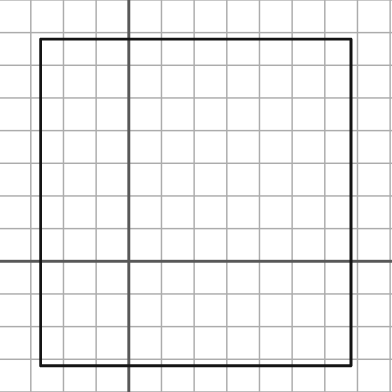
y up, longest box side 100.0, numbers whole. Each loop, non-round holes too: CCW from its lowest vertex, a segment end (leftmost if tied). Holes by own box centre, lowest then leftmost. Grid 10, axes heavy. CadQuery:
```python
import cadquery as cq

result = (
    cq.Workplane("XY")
    .moveTo(-27.0, -32.0)
    .lineTo(68.0, -32.0)
    .lineTo(68.0, 68.0)
    .lineTo(-27.0, 68.0)
    .close()
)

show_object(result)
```